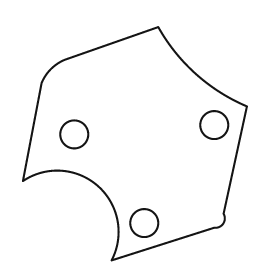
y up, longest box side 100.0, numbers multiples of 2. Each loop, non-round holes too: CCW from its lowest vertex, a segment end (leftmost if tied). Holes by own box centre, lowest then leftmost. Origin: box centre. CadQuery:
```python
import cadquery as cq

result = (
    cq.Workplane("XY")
    .moveTo(-10.0, -50.0)
    .lineTo(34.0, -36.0)
    .threePointArc((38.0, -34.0), (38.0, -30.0))
    .lineTo(48.0, 16.0)
    .threePointArc((26.0, 30.0), (10.0, 50.0))
    .lineTo(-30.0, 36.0)
    .threePointArc((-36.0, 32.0), (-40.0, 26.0))
    .lineTo(-48.0, -16.0)
    .threePointArc((-16.0, -18.0), (-10.0, -50.0))
    .close()
    .moveTo(4.0, -34.0)
    .circle(6.0)
    .moveTo(-26.0, 4.0)
    .circle(6.0)
    .moveTo(34.0, 8.0)
    .circle(6.0)
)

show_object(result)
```